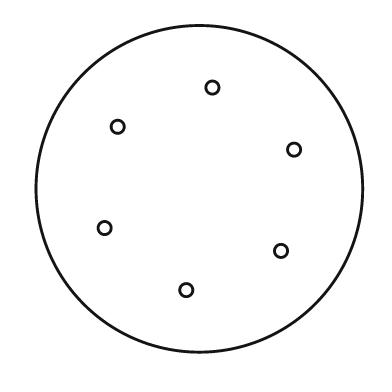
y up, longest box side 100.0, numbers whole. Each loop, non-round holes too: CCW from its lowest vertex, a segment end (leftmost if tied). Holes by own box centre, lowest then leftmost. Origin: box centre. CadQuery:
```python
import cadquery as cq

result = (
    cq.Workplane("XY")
    .moveTo(0.0, 0.0)
    .circle(50.0)
    .moveTo(-4.0, -31.0)
    .circle(2.0)
    .moveTo(25.0, -19.0)
    .circle(2.0)
    .moveTo(-29.0, -12.0)
    .circle(2.0)
    .moveTo(29.0, 12.0)
    .circle(2.0)
    .moveTo(-25.0, 19.0)
    .circle(2.0)
    .moveTo(4.0, 31.0)
    .circle(2.0)
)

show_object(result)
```